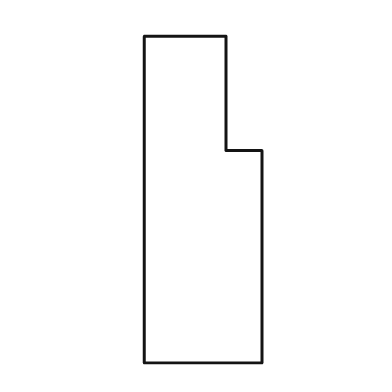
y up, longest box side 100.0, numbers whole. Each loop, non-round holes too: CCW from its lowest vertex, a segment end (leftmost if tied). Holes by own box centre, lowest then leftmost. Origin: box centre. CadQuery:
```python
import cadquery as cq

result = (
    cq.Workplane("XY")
    .moveTo(-18.0, -50.0)
    .lineTo(18.0, -50.0)
    .lineTo(18.0, 15.0)
    .lineTo(7.0, 15.0)
    .lineTo(7.0, 50.0)
    .lineTo(-18.0, 50.0)
    .close()
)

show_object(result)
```